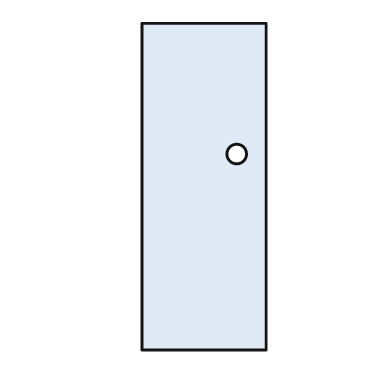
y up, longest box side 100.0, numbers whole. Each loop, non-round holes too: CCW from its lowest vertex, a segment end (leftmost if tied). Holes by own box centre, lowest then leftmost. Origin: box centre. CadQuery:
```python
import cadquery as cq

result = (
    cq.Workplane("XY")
    .moveTo(-19.0, -50.0)
    .lineTo(19.0, -50.0)
    .lineTo(19.0, 50.0)
    .lineTo(-19.0, 50.0)
    .close()
    .moveTo(10.0, 10.0)
    .circle(3.0)
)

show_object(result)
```